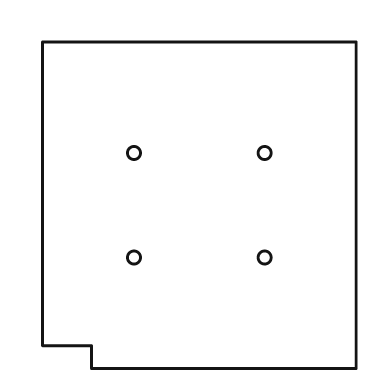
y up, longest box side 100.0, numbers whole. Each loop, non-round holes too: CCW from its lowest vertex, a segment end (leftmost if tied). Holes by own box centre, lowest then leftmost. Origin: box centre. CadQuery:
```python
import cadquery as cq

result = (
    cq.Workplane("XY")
    .moveTo(-33.0, -50.0)
    .lineTo(48.0, -50.0)
    .lineTo(48.0, 50.0)
    .lineTo(-48.0, 50.0)
    .lineTo(-48.0, -43.0)
    .lineTo(-33.0, -43.0)
    .close()
    .moveTo(-20.0, -16.0)
    .circle(2.0)
    .moveTo(20.0, -16.0)
    .circle(2.0)
    .moveTo(-20.0, 16.0)
    .circle(2.0)
    .moveTo(20.0, 16.0)
    .circle(2.0)
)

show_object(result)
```